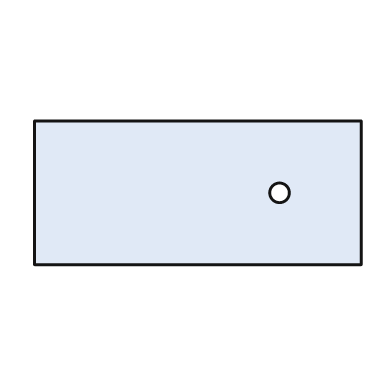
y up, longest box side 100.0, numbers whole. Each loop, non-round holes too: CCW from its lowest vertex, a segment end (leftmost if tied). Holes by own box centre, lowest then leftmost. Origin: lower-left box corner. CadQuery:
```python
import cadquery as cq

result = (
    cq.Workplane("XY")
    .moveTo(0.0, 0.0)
    .lineTo(100.0, 0.0)
    .lineTo(100.0, 44.0)
    .lineTo(0.0, 44.0)
    .close()
    .moveTo(75.0, 22.0)
    .circle(3.0)
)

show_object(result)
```